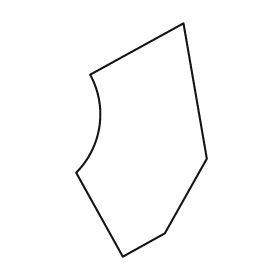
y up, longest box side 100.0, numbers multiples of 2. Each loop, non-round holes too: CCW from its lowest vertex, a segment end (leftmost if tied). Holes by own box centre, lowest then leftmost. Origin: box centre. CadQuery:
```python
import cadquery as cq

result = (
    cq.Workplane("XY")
    .moveTo(-8.0, -50.0)
    .lineTo(10.0, -40.0)
    .lineTo(28.0, -8.0)
    .lineTo(18.0, 50.0)
    .lineTo(-22.0, 28.0)
    .threePointArc((-18.0, 6.0), (-28.0, -14.0))
    .close()
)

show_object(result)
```